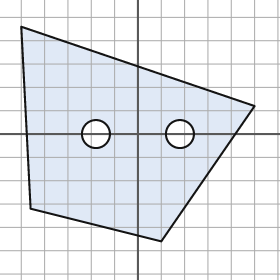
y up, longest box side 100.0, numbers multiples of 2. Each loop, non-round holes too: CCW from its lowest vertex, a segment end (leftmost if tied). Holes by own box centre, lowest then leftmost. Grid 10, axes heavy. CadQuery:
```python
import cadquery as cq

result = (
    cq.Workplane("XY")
    .moveTo(10.0, -46.0)
    .lineTo(50.0, 12.0)
    .lineTo(-50.0, 46.0)
    .lineTo(-46.0, -32.0)
    .close()
    .moveTo(-18.0, 0.0)
    .circle(6.0)
    .moveTo(18.0, 0.0)
    .circle(6.0)
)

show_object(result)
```